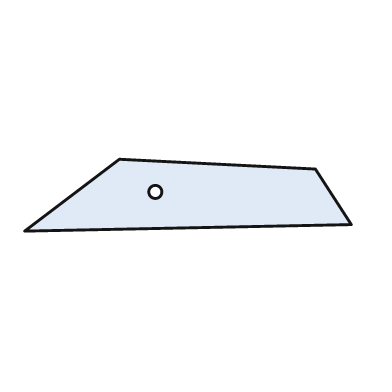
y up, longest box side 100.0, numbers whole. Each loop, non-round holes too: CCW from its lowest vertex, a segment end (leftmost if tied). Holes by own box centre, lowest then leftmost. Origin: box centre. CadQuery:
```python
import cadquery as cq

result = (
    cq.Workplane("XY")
    .moveTo(-50.0, -11.0)
    .lineTo(50.0, -9.0)
    .lineTo(39.0, 8.0)
    .lineTo(-21.0, 11.0)
    .close()
    .moveTo(-10.0, 1.0)
    .circle(2.0)
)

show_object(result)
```